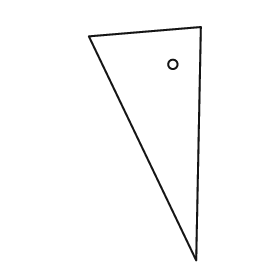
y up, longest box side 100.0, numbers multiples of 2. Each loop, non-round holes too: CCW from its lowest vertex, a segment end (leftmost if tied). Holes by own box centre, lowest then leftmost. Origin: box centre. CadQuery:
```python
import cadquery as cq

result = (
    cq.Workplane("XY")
    .moveTo(22.0, -50.0)
    .lineTo(24.0, 50.0)
    .lineTo(-24.0, 46.0)
    .close()
    .moveTo(12.0, 34.0)
    .circle(2.0)
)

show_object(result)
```